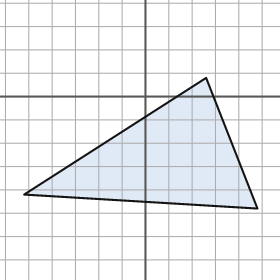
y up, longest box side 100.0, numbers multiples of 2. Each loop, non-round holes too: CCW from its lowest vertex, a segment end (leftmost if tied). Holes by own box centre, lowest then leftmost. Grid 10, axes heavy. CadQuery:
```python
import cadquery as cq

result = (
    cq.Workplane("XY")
    .moveTo(48.0, -48.0)
    .lineTo(26.0, 8.0)
    .lineTo(-52.0, -42.0)
    .close()
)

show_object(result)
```